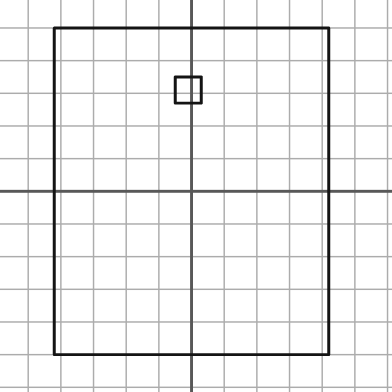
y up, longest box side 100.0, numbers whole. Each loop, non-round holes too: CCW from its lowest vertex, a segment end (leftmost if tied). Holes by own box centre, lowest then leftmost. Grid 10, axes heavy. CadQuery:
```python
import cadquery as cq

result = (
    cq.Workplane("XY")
    .moveTo(-42.0, -50.0)
    .lineTo(42.0, -50.0)
    .lineTo(42.0, 50.0)
    .lineTo(-42.0, 50.0)
    .close()
    .moveTo(-5.0, 27.0)
    .lineTo(3.0, 27.0)
    .lineTo(3.0, 35.0)
    .lineTo(-5.0, 35.0)
    .close()
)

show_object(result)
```